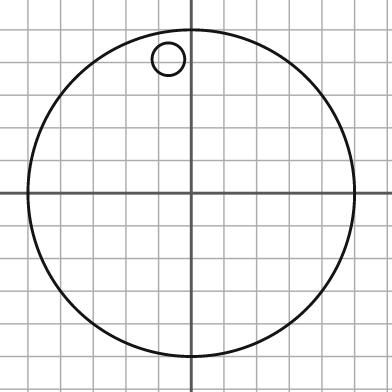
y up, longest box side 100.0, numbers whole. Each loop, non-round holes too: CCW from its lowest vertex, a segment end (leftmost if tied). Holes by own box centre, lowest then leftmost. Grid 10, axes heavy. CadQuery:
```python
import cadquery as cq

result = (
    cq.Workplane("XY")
    .moveTo(0.0, 0.0)
    .circle(50.0)
    .moveTo(-7.0, 41.0)
    .circle(5.0)
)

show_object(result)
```